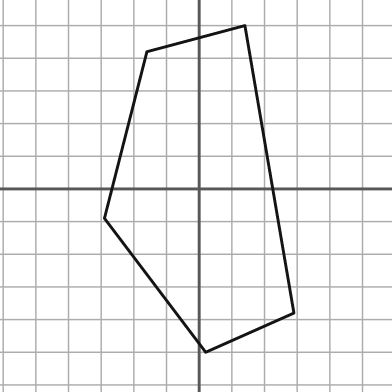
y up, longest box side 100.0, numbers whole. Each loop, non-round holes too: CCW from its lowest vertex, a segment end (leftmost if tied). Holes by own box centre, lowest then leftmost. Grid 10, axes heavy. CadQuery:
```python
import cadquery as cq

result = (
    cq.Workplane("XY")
    .moveTo(2.0, -50.0)
    .lineTo(29.0, -38.0)
    .lineTo(14.0, 50.0)
    .lineTo(-16.0, 42.0)
    .lineTo(-29.0, -9.0)
    .close()
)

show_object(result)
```